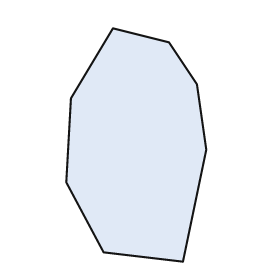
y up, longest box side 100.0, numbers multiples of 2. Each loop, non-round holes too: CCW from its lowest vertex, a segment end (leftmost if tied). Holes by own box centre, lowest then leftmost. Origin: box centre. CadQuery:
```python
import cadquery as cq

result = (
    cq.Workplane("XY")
    .moveTo(20.0, -50.0)
    .lineTo(30.0, -2.0)
    .lineTo(26.0, 26.0)
    .lineTo(14.0, 44.0)
    .lineTo(-10.0, 50.0)
    .lineTo(-28.0, 20.0)
    .lineTo(-30.0, -16.0)
    .lineTo(-14.0, -46.0)
    .close()
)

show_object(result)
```